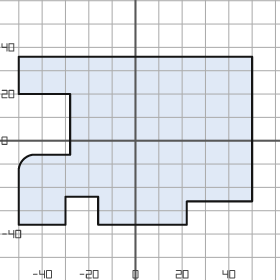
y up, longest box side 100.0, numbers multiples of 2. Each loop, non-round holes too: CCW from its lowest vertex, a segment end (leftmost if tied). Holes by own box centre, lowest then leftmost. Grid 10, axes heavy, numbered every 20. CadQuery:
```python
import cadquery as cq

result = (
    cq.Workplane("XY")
    .moveTo(-50.0, -36.0)
    .lineTo(-30.0, -36.0)
    .lineTo(-30.0, -24.0)
    .lineTo(-16.0, -24.0)
    .lineTo(-16.0, -36.0)
    .lineTo(22.0, -36.0)
    .lineTo(22.0, -26.0)
    .lineTo(50.0, -26.0)
    .lineTo(50.0, 36.0)
    .lineTo(-50.0, 36.0)
    .lineTo(-50.0, 20.0)
    .lineTo(-28.0, 20.0)
    .lineTo(-28.0, -6.0)
    .lineTo(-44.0, -6.0)
    .threePointArc((-48.0, -8.0), (-50.0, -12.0))
    .close()
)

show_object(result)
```